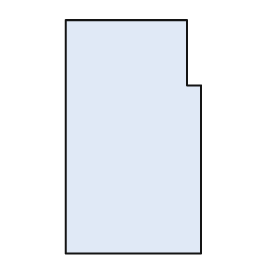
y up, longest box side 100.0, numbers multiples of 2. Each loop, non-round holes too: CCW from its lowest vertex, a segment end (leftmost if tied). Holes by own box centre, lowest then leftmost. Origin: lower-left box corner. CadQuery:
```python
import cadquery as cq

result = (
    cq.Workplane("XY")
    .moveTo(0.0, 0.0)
    .lineTo(58.0, 0.0)
    .lineTo(58.0, 72.0)
    .lineTo(52.0, 72.0)
    .lineTo(52.0, 100.0)
    .lineTo(0.0, 100.0)
    .close()
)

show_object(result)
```